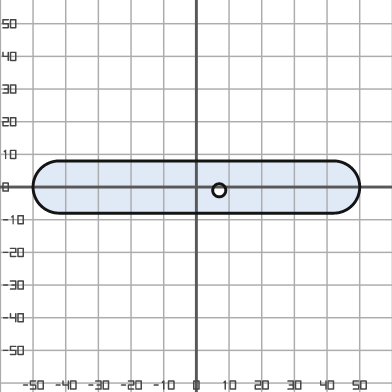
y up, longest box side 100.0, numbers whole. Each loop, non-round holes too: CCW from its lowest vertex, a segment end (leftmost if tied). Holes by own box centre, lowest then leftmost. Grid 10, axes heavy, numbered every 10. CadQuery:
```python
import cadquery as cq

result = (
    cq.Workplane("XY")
    .moveTo(-42.0, -8.0)
    .lineTo(42.0, -8.0)
    .threePointArc((50.0, 0.0), (42.0, 8.0))
    .lineTo(-42.0, 8.0)
    .threePointArc((-50.0, 0.0), (-42.0, -8.0))
    .close()
    .moveTo(7.0, -1.0)
    .circle(2.0)
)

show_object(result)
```